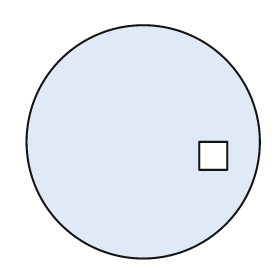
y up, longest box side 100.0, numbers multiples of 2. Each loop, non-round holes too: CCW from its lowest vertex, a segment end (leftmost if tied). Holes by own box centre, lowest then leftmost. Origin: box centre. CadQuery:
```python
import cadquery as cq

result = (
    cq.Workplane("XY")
    .moveTo(0.0, 0.0)
    .circle(50.0)
    .moveTo(24.0, -12.0)
    .lineTo(36.0, -12.0)
    .lineTo(36.0, 0.0)
    .lineTo(24.0, 0.0)
    .close()
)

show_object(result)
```